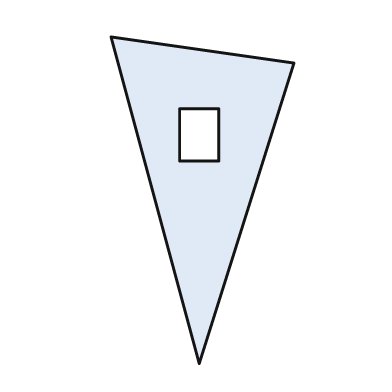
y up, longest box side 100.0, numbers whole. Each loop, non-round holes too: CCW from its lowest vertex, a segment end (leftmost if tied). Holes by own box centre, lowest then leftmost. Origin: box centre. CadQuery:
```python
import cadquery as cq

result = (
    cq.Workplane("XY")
    .moveTo(-1.0, -50.0)
    .lineTo(28.0, 42.0)
    .lineTo(-28.0, 50.0)
    .close()
    .moveTo(-7.0, 12.0)
    .lineTo(5.0, 12.0)
    .lineTo(5.0, 28.0)
    .lineTo(-7.0, 28.0)
    .close()
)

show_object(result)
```